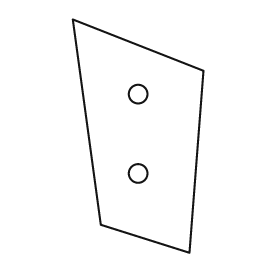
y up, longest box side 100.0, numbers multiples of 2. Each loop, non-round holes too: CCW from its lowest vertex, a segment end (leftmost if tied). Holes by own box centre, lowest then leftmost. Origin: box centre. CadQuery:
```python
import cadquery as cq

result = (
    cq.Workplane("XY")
    .moveTo(22.0, -50.0)
    .lineTo(28.0, 28.0)
    .lineTo(-28.0, 50.0)
    .lineTo(-16.0, -38.0)
    .close()
    .moveTo(0.0, -16.0)
    .circle(4.0)
    .moveTo(0.0, 18.0)
    .circle(4.0)
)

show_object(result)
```